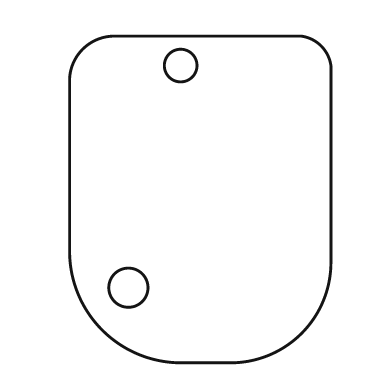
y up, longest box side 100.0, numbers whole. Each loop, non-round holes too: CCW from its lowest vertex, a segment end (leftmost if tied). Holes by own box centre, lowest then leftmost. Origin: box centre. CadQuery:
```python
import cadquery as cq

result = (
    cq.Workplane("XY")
    .moveTo(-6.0, -50.0)
    .lineTo(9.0, -50.0)
    .threePointArc((31.0, -41.0), (40.0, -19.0))
    .lineTo(40.0, 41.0)
    .threePointArc((37.0, 47.0), (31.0, 50.0))
    .lineTo(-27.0, 50.0)
    .threePointArc((-36.0, 46.0), (-40.0, 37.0))
    .lineTo(-40.0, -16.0)
    .threePointArc((-30.0, -40.0), (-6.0, -50.0))
    .close()
    .moveTo(-22.0, -27.0)
    .circle(6.0)
    .moveTo(-6.0, 41.0)
    .circle(5.0)
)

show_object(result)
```